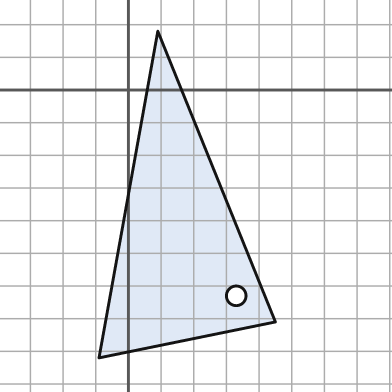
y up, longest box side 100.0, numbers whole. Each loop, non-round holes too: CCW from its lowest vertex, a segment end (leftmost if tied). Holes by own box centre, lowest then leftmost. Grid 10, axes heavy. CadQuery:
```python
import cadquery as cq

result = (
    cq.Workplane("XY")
    .moveTo(-9.0, -82.0)
    .lineTo(45.0, -71.0)
    .lineTo(9.0, 18.0)
    .close()
    .moveTo(33.0, -63.0)
    .circle(3.0)
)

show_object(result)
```